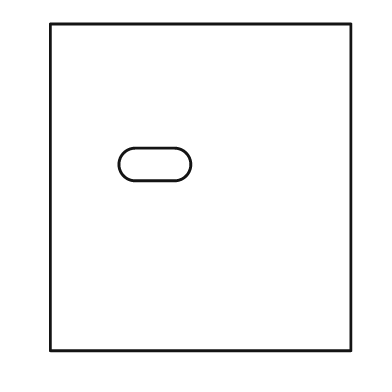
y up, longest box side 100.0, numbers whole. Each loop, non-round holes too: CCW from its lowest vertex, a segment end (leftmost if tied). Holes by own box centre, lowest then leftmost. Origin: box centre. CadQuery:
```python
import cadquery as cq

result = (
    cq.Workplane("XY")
    .moveTo(-46.0, -50.0)
    .lineTo(46.0, -50.0)
    .lineTo(46.0, 50.0)
    .lineTo(-46.0, 50.0)
    .close()
    .moveTo(-20.0, 2.0)
    .lineTo(-8.0, 2.0)
    .threePointArc((-3.0, 7.0), (-8.0, 12.0))
    .lineTo(-20.0, 12.0)
    .threePointArc((-25.0, 7.0), (-20.0, 2.0))
    .close()
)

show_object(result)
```